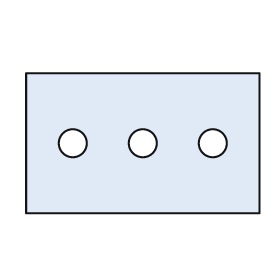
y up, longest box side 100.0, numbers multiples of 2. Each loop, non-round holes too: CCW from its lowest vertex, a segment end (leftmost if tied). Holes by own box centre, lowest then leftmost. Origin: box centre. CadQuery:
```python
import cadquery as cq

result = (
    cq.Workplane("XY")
    .moveTo(-50.0, -30.0)
    .lineTo(50.0, -30.0)
    .lineTo(50.0, 30.0)
    .lineTo(-50.0, 30.0)
    .close()
    .moveTo(-30.0, 0.0)
    .circle(6.0)
    .moveTo(0.0, 0.0)
    .circle(6.0)
    .moveTo(30.0, 0.0)
    .circle(6.0)
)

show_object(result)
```